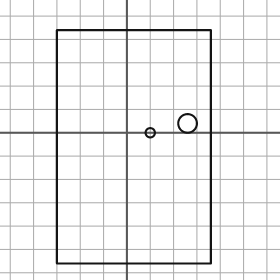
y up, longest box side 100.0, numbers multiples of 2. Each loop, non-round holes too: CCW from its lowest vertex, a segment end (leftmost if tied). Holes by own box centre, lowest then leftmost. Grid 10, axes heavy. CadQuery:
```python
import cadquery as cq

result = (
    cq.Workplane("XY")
    .moveTo(-30.0, -56.0)
    .lineTo(36.0, -56.0)
    .lineTo(36.0, 44.0)
    .lineTo(-30.0, 44.0)
    .close()
    .moveTo(10.0, 0.0)
    .circle(2.0)
    .moveTo(26.0, 4.0)
    .circle(4.0)
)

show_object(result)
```